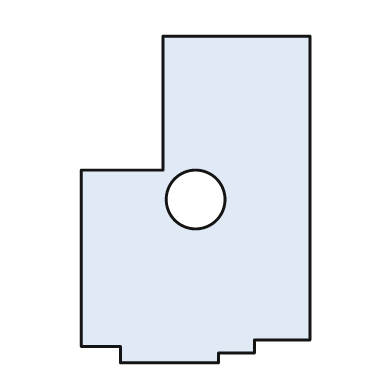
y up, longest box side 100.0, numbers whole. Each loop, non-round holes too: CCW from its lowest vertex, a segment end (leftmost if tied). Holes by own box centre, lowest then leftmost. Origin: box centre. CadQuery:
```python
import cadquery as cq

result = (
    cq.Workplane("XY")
    .moveTo(-23.0, -50.0)
    .lineTo(7.0, -50.0)
    .lineTo(7.0, -47.0)
    .lineTo(18.0, -47.0)
    .lineTo(18.0, -43.0)
    .lineTo(35.0, -43.0)
    .lineTo(35.0, 50.0)
    .lineTo(-10.0, 50.0)
    .lineTo(-10.0, 9.0)
    .lineTo(-35.0, 9.0)
    .lineTo(-35.0, -45.0)
    .lineTo(-23.0, -45.0)
    .close()
    .moveTo(0.0, 0.0)
    .circle(9.0)
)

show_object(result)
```